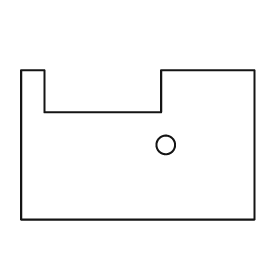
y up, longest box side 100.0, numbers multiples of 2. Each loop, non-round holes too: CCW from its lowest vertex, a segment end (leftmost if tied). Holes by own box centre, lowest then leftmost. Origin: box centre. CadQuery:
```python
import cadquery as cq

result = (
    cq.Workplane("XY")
    .moveTo(-50.0, -32.0)
    .lineTo(50.0, -32.0)
    .lineTo(50.0, 32.0)
    .lineTo(10.0, 32.0)
    .lineTo(10.0, 14.0)
    .lineTo(-40.0, 14.0)
    .lineTo(-40.0, 32.0)
    .lineTo(-50.0, 32.0)
    .close()
    .moveTo(12.0, 0.0)
    .circle(4.0)
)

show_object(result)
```